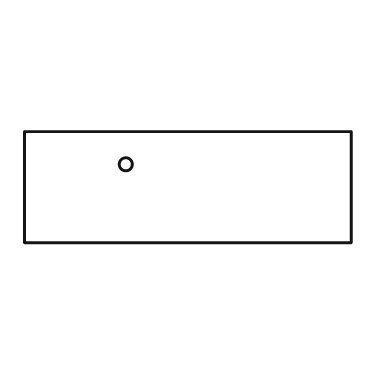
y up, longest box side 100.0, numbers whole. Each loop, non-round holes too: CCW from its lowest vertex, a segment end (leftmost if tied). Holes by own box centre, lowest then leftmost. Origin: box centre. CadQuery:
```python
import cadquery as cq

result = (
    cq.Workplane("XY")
    .moveTo(-50.0, -17.0)
    .lineTo(50.0, -17.0)
    .lineTo(50.0, 17.0)
    .lineTo(-50.0, 17.0)
    .close()
    .moveTo(-19.0, 7.0)
    .circle(2.0)
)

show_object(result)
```